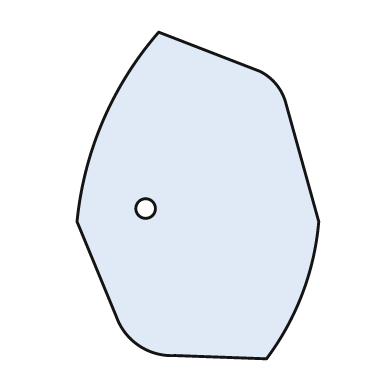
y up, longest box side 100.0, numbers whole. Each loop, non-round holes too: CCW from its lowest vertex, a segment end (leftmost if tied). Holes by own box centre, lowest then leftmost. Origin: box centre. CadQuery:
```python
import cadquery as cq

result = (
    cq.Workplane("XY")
    .moveTo(21.0, -50.0)
    .threePointArc((32.0, -30.0), (37.0, -8.0))
    .lineTo(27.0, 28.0)
    .threePointArc((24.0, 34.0), (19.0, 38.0))
    .lineTo(-12.0, 50.0)
    .threePointArc((-29.0, 23.0), (-37.0, -8.0))
    .lineTo(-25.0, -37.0)
    .threePointArc((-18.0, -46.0), (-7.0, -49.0))
    .close()
    .moveTo(-16.0, -4.0)
    .circle(3.0)
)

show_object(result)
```